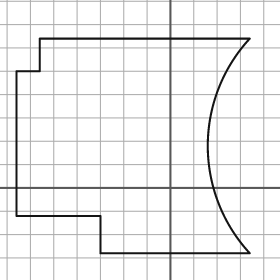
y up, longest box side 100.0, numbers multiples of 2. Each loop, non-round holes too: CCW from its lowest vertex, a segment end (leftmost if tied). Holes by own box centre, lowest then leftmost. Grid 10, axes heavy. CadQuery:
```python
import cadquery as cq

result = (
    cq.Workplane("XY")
    .moveTo(-30.0, -28.0)
    .lineTo(34.0, -28.0)
    .threePointArc((16.0, 18.0), (34.0, 64.0))
    .lineTo(-56.0, 64.0)
    .lineTo(-56.0, 50.0)
    .lineTo(-66.0, 50.0)
    .lineTo(-66.0, -12.0)
    .lineTo(-30.0, -12.0)
    .close()
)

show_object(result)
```